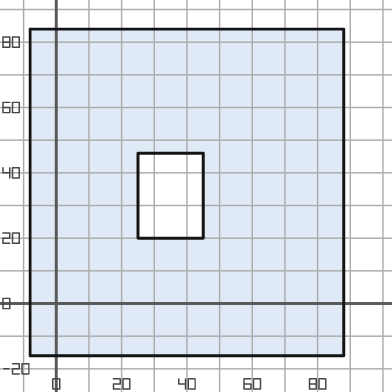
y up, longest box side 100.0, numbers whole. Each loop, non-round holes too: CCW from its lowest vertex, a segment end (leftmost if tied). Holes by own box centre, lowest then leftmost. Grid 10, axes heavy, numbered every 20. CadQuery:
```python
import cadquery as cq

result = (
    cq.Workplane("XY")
    .moveTo(-8.0, -16.0)
    .lineTo(88.0, -16.0)
    .lineTo(88.0, 84.0)
    .lineTo(-8.0, 84.0)
    .close()
    .moveTo(25.0, 20.0)
    .lineTo(45.0, 20.0)
    .lineTo(45.0, 46.0)
    .lineTo(25.0, 46.0)
    .close()
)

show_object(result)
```